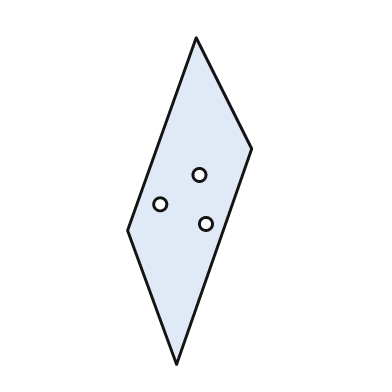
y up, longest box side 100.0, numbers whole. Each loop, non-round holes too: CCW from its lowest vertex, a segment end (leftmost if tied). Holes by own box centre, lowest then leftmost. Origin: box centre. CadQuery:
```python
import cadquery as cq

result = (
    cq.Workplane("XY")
    .moveTo(-4.0, -50.0)
    .lineTo(19.0, 16.0)
    .lineTo(2.0, 50.0)
    .lineTo(-19.0, -9.0)
    .close()
    .moveTo(5.0, -7.0)
    .circle(2.0)
    .moveTo(-9.0, -1.0)
    .circle(2.0)
    .moveTo(3.0, 8.0)
    .circle(2.0)
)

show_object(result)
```